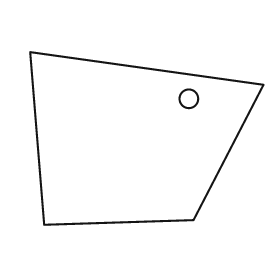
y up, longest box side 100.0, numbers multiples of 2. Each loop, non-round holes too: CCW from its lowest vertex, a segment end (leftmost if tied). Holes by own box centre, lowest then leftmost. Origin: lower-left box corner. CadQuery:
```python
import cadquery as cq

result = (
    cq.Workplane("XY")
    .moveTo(6.0, 0.0)
    .lineTo(70.0, 2.0)
    .lineTo(100.0, 60.0)
    .lineTo(0.0, 74.0)
    .close()
    .moveTo(68.0, 54.0)
    .circle(4.0)
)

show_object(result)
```